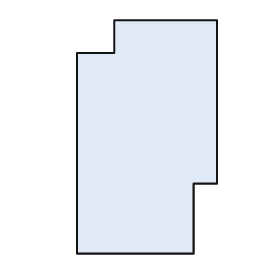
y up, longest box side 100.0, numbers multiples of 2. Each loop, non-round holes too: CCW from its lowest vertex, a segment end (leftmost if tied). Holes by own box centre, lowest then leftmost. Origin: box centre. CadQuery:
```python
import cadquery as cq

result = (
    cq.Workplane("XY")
    .moveTo(-30.0, -50.0)
    .lineTo(20.0, -50.0)
    .lineTo(20.0, -20.0)
    .lineTo(30.0, -20.0)
    .lineTo(30.0, 50.0)
    .lineTo(-14.0, 50.0)
    .lineTo(-14.0, 36.0)
    .lineTo(-30.0, 36.0)
    .close()
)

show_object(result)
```